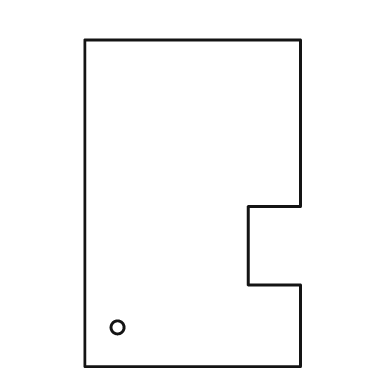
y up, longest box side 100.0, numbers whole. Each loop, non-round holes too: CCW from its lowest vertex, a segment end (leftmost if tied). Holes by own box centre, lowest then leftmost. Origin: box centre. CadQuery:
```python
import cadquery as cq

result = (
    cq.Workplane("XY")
    .moveTo(-33.0, -50.0)
    .lineTo(33.0, -50.0)
    .lineTo(33.0, -25.0)
    .lineTo(17.0, -25.0)
    .lineTo(17.0, -1.0)
    .lineTo(33.0, -1.0)
    .lineTo(33.0, 50.0)
    .lineTo(-33.0, 50.0)
    .close()
    .moveTo(-23.0, -38.0)
    .circle(2.0)
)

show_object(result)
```